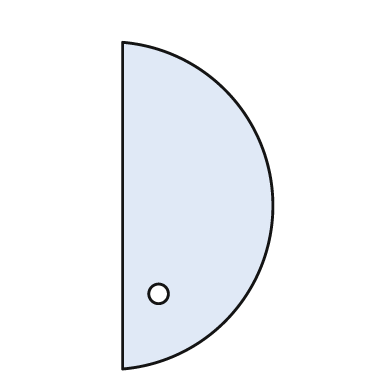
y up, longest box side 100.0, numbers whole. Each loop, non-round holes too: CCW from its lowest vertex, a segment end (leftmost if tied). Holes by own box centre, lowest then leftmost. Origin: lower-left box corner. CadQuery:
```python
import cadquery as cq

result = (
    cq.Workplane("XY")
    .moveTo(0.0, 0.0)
    .threePointArc((46.0, 50.0), (0.0, 100.0))
    .close()
    .moveTo(11.0, 23.0)
    .circle(3.0)
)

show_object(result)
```